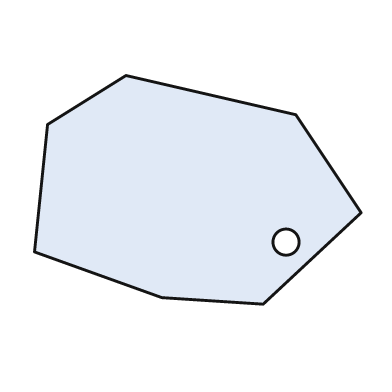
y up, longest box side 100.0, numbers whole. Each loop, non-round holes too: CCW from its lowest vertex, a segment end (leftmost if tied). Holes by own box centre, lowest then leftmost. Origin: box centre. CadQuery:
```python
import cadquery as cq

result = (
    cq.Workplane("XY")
    .moveTo(20.0, -35.0)
    .lineTo(50.0, -7.0)
    .lineTo(30.0, 23.0)
    .lineTo(-22.0, 35.0)
    .lineTo(-46.0, 20.0)
    .lineTo(-50.0, -19.0)
    .lineTo(-11.0, -33.0)
    .close()
    .moveTo(27.0, -16.0)
    .circle(4.0)
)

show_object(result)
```